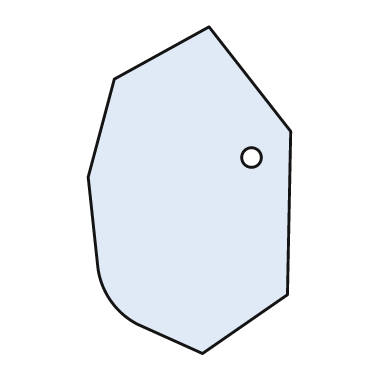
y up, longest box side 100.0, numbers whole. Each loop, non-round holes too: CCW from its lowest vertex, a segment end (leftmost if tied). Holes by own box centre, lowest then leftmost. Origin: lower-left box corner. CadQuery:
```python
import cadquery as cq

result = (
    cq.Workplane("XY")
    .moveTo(35.0, 0.0)
    .lineTo(61.0, 18.0)
    .lineTo(62.0, 68.0)
    .lineTo(37.0, 100.0)
    .lineTo(8.0, 84.0)
    .lineTo(0.0, 54.0)
    .lineTo(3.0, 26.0)
    .threePointArc((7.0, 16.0), (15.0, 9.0))
    .close()
    .moveTo(50.0, 60.0)
    .circle(3.0)
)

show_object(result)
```